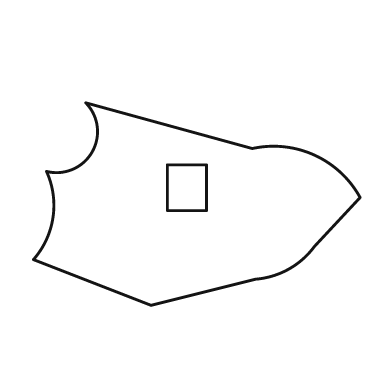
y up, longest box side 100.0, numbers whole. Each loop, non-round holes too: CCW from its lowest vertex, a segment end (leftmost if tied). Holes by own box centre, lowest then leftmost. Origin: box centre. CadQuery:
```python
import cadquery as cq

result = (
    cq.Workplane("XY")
    .moveTo(-14.0, -31.0)
    .lineTo(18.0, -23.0)
    .threePointArc((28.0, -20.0), (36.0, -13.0))
    .lineTo(50.0, 2.0)
    .threePointArc((36.0, 15.0), (17.0, 17.0))
    .lineTo(-34.0, 31.0)
    .threePointArc((-32.0, 16.0), (-46.0, 10.0))
    .threePointArc((-44.0, -4.0), (-50.0, -17.0))
    .close()
    .moveTo(-9.0, -2.0)
    .lineTo(3.0, -2.0)
    .lineTo(3.0, 12.0)
    .lineTo(-9.0, 12.0)
    .close()
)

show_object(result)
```